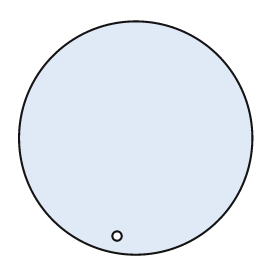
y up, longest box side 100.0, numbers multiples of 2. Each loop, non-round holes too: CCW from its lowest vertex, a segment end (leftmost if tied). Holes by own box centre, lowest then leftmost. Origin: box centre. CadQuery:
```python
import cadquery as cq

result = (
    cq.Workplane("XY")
    .moveTo(0.0, 0.0)
    .circle(50.0)
    .moveTo(-8.0, -42.0)
    .circle(2.0)
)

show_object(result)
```